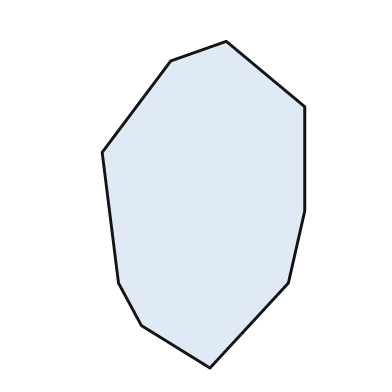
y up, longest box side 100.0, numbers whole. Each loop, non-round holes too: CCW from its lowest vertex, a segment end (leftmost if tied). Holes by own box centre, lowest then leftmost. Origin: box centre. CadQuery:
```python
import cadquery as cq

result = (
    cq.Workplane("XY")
    .moveTo(2.0, -50.0)
    .lineTo(26.0, -24.0)
    .lineTo(31.0, -2.0)
    .lineTo(31.0, 30.0)
    .lineTo(7.0, 50.0)
    .lineTo(-10.0, 44.0)
    .lineTo(-31.0, 16.0)
    .lineTo(-26.0, -24.0)
    .lineTo(-19.0, -37.0)
    .close()
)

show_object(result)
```